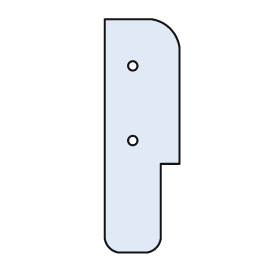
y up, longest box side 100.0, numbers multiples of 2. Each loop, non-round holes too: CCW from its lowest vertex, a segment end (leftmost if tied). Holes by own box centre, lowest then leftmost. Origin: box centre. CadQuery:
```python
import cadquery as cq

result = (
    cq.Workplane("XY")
    .moveTo(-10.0, -50.0)
    .lineTo(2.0, -50.0)
    .threePointArc((6.0, -48.0), (8.0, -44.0))
    .lineTo(8.0, -12.0)
    .lineTo(16.0, -12.0)
    .lineTo(16.0, 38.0)
    .threePointArc((12.0, 46.0), (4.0, 50.0))
    .lineTo(-16.0, 50.0)
    .lineTo(-16.0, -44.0)
    .threePointArc((-14.0, -48.0), (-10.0, -50.0))
    .close()
    .moveTo(-4.0, -2.0)
    .circle(2.0)
    .moveTo(-4.0, 30.0)
    .circle(2.0)
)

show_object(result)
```